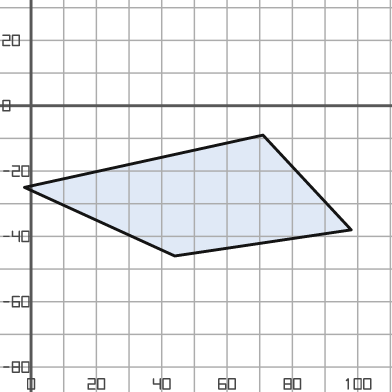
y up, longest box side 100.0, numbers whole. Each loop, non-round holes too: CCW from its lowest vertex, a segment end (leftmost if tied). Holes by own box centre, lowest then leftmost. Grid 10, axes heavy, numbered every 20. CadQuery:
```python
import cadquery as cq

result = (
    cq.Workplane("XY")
    .moveTo(44.0, -46.0)
    .lineTo(98.0, -38.0)
    .lineTo(71.0, -9.0)
    .lineTo(-2.0, -25.0)
    .close()
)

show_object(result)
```